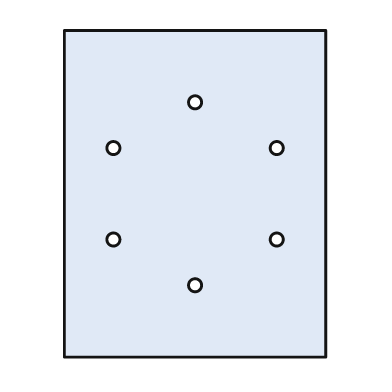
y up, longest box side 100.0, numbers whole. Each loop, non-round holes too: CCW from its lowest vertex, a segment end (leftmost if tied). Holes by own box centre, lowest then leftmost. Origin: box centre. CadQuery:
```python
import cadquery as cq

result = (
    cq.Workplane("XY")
    .moveTo(-40.0, -50.0)
    .lineTo(40.0, -50.0)
    .lineTo(40.0, 50.0)
    .lineTo(-40.0, 50.0)
    .close()
    .moveTo(0.0, -28.0)
    .circle(2.0)
    .moveTo(-25.0, -14.0)
    .circle(2.0)
    .moveTo(25.0, -14.0)
    .circle(2.0)
    .moveTo(-25.0, 14.0)
    .circle(2.0)
    .moveTo(25.0, 14.0)
    .circle(2.0)
    .moveTo(0.0, 28.0)
    .circle(2.0)
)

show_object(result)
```